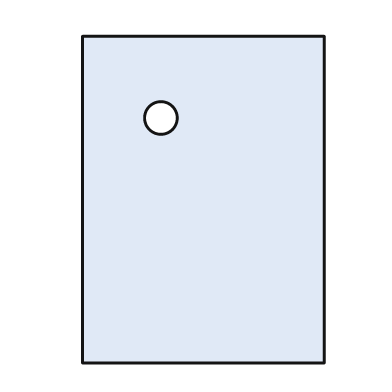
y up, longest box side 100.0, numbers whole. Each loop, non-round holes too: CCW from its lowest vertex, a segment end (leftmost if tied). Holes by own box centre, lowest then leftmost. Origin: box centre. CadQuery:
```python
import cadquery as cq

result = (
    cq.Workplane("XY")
    .moveTo(-37.0, -50.0)
    .lineTo(37.0, -50.0)
    .lineTo(37.0, 50.0)
    .lineTo(-37.0, 50.0)
    .close()
    .moveTo(-13.0, 25.0)
    .circle(5.0)
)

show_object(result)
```